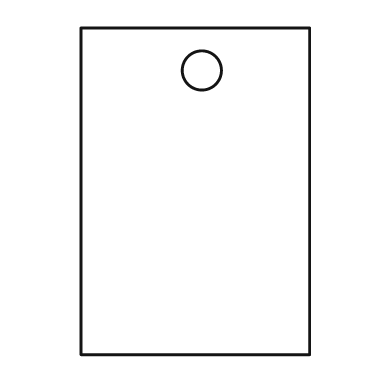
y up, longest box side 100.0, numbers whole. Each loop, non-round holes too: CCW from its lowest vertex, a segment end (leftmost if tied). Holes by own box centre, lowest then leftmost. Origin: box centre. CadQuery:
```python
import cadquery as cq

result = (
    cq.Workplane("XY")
    .moveTo(-35.0, -50.0)
    .lineTo(35.0, -50.0)
    .lineTo(35.0, 50.0)
    .lineTo(-35.0, 50.0)
    .close()
    .moveTo(2.0, 37.0)
    .circle(6.0)
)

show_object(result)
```